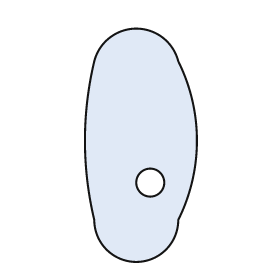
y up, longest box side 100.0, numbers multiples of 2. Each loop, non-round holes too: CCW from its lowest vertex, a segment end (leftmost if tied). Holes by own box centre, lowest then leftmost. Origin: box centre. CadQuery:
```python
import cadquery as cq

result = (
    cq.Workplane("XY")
    .moveTo(-20.0, -32.0)
    .threePointArc((-2.0, -50.0), (16.0, -32.0))
    .threePointArc((24.0, 2.0), (16.0, 36.0))
    .threePointArc((-2.0, 50.0), (-20.0, 36.0))
    .threePointArc((-24.0, 2.0), (-20.0, -32.0))
    .close()
    .moveTo(4.0, -16.0)
    .circle(6.0)
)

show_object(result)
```